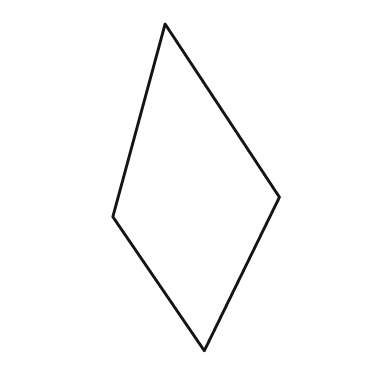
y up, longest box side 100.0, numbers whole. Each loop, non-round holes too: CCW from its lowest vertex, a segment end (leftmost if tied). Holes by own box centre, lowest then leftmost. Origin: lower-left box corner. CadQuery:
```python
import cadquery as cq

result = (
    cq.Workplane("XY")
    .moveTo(28.0, 0.0)
    .lineTo(51.0, 47.0)
    .lineTo(16.0, 100.0)
    .lineTo(0.0, 41.0)
    .close()
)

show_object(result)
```